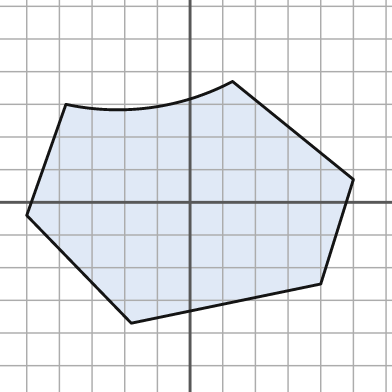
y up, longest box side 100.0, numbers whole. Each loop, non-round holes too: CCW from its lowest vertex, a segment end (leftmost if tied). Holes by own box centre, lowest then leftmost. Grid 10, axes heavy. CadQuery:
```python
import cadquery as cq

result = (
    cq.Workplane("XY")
    .moveTo(-18.0, -37.0)
    .lineTo(40.0, -25.0)
    .lineTo(50.0, 7.0)
    .lineTo(13.0, 37.0)
    .threePointArc((-12.0, 29.0), (-38.0, 30.0))
    .lineTo(-50.0, -4.0)
    .close()
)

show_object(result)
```